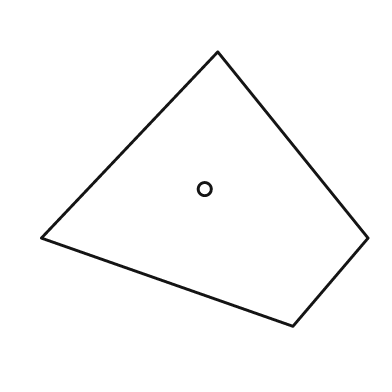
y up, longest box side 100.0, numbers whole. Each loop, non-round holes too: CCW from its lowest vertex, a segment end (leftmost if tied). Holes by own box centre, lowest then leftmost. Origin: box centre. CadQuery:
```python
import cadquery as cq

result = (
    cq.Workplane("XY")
    .moveTo(27.0, -42.0)
    .lineTo(50.0, -15.0)
    .lineTo(4.0, 42.0)
    .lineTo(-50.0, -15.0)
    .close()
    .moveTo(0.0, 0.0)
    .circle(2.0)
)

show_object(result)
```